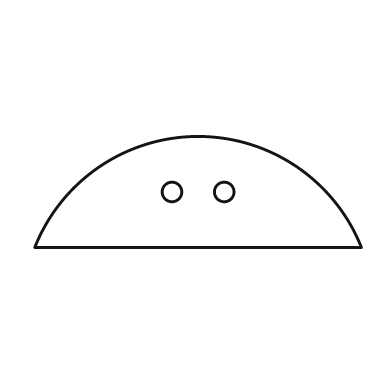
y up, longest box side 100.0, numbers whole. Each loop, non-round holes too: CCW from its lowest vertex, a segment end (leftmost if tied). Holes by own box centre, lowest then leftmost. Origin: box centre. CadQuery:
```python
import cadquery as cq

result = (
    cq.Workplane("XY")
    .moveTo(-50.0, -17.0)
    .lineTo(50.0, -17.0)
    .threePointArc((0.0, 17.0), (-50.0, -17.0))
    .close()
    .moveTo(-8.0, 0.0)
    .circle(3.0)
    .moveTo(8.0, 0.0)
    .circle(3.0)
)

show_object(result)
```